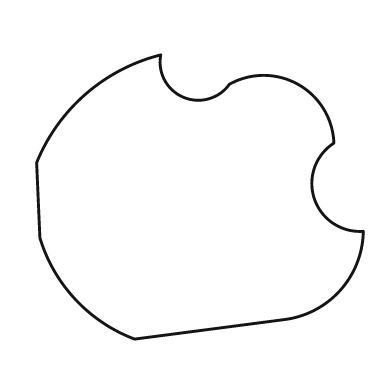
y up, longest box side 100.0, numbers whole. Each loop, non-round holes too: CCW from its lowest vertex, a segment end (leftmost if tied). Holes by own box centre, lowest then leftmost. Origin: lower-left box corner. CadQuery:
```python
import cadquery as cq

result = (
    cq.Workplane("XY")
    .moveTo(30.0, 0.0)
    .lineTo(76.0, 6.0)
    .threePointArc((93.0, 15.0), (100.0, 33.0))
    .threePointArc((85.0, 43.0), (91.0, 60.0))
    .threePointArc((80.0, 78.0), (59.0, 78.0))
    .threePointArc((45.0, 74.0), (38.0, 87.0))
    .threePointArc((15.0, 75.0), (0.0, 54.0))
    .lineTo(1.0, 31.0)
    .threePointArc((12.0, 12.0), (30.0, 0.0))
    .close()
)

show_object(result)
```